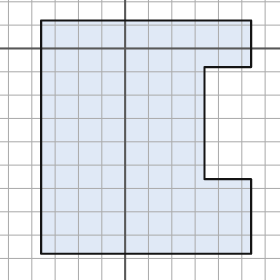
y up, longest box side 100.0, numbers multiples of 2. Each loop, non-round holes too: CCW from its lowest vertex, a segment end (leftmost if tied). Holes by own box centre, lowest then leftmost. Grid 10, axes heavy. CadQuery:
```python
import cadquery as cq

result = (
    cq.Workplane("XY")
    .moveTo(-36.0, -88.0)
    .lineTo(54.0, -88.0)
    .lineTo(54.0, -56.0)
    .lineTo(34.0, -56.0)
    .lineTo(34.0, -8.0)
    .lineTo(54.0, -8.0)
    .lineTo(54.0, 12.0)
    .lineTo(-36.0, 12.0)
    .close()
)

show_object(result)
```